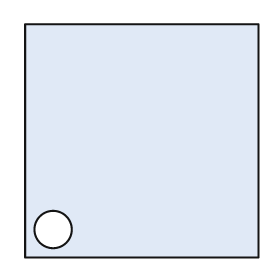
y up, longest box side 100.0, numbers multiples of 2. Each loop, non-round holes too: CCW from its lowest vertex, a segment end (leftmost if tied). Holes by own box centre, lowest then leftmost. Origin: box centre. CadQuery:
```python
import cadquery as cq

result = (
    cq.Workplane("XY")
    .moveTo(-50.0, -50.0)
    .lineTo(50.0, -50.0)
    .lineTo(50.0, 50.0)
    .lineTo(-50.0, 50.0)
    .close()
    .moveTo(-38.0, -38.0)
    .circle(8.0)
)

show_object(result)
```